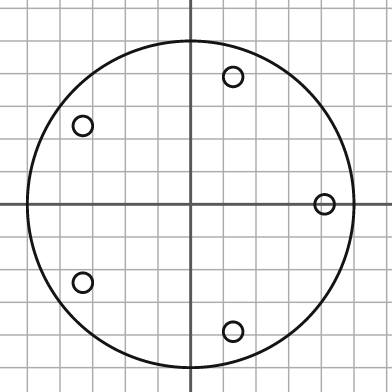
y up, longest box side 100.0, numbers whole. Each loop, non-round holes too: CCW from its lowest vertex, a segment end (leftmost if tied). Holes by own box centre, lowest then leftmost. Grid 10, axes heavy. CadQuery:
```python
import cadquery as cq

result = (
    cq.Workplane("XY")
    .moveTo(0.0, 0.0)
    .circle(50.0)
    .moveTo(13.0, -39.0)
    .circle(3.0)
    .moveTo(-33.0, -24.0)
    .circle(3.0)
    .moveTo(41.0, 0.0)
    .circle(3.0)
    .moveTo(-33.0, 24.0)
    .circle(3.0)
    .moveTo(13.0, 39.0)
    .circle(3.0)
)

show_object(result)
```